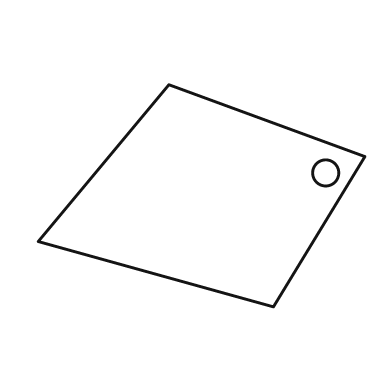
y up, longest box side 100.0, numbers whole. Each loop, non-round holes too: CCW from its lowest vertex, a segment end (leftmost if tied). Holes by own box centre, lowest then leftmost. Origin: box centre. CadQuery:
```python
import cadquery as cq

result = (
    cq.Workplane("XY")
    .moveTo(22.0, -34.0)
    .lineTo(50.0, 12.0)
    .lineTo(-10.0, 34.0)
    .lineTo(-50.0, -14.0)
    .close()
    .moveTo(38.0, 7.0)
    .circle(4.0)
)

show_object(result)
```